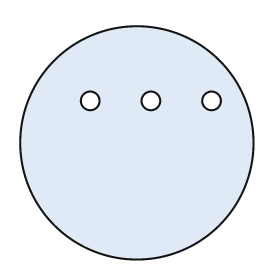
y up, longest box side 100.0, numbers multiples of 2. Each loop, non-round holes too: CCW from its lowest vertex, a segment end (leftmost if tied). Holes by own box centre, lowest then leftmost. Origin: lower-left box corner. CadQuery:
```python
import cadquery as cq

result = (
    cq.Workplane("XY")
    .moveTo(50.0, 50.0)
    .circle(50.0)
    .moveTo(30.0, 68.0)
    .circle(4.0)
    .moveTo(56.0, 68.0)
    .circle(4.0)
    .moveTo(82.0, 68.0)
    .circle(4.0)
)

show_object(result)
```